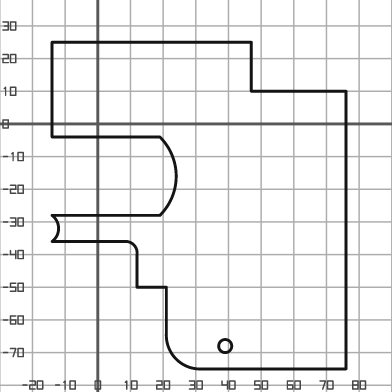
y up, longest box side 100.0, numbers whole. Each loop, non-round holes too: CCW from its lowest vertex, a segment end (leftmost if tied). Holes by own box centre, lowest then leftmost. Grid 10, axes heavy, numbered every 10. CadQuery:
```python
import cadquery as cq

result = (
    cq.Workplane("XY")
    .moveTo(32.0, -75.0)
    .lineTo(76.0, -75.0)
    .lineTo(76.0, 10.0)
    .lineTo(47.0, 10.0)
    .lineTo(47.0, 25.0)
    .lineTo(-14.0, 25.0)
    .lineTo(-14.0, -4.0)
    .lineTo(19.0, -4.0)
    .threePointArc((24.0, -16.0), (19.0, -28.0))
    .lineTo(-14.0, -28.0)
    .threePointArc((-12.0, -32.0), (-14.0, -36.0))
    .lineTo(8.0, -36.0)
    .threePointArc((11.0, -37.0), (12.0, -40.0))
    .lineTo(12.0, -50.0)
    .lineTo(21.0, -50.0)
    .lineTo(21.0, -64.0)
    .threePointArc((24.0, -72.0), (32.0, -75.0))
    .close()
    .moveTo(39.0, -68.0)
    .circle(2.0)
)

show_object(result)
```